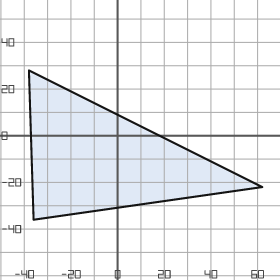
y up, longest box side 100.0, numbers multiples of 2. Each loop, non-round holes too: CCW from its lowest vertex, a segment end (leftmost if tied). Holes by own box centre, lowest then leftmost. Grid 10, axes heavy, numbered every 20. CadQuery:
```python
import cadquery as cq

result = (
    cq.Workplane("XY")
    .moveTo(-36.0, -36.0)
    .lineTo(62.0, -22.0)
    .lineTo(-38.0, 28.0)
    .close()
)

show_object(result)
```